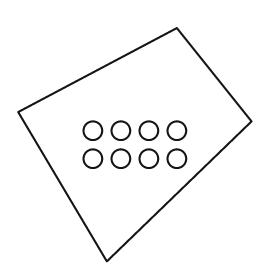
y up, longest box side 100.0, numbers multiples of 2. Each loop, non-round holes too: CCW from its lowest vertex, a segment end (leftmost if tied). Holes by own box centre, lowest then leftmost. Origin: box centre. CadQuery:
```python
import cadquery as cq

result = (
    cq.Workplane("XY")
    .moveTo(-12.0, -50.0)
    .lineTo(50.0, 10.0)
    .lineTo(18.0, 50.0)
    .lineTo(-50.0, 14.0)
    .close()
    .moveTo(-18.0, -6.0)
    .circle(4.0)
    .moveTo(-6.0, -6.0)
    .circle(4.0)
    .moveTo(6.0, -6.0)
    .circle(4.0)
    .moveTo(18.0, -6.0)
    .circle(4.0)
    .moveTo(-18.0, 6.0)
    .circle(4.0)
    .moveTo(-6.0, 6.0)
    .circle(4.0)
    .moveTo(6.0, 6.0)
    .circle(4.0)
    .moveTo(18.0, 6.0)
    .circle(4.0)
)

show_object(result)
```